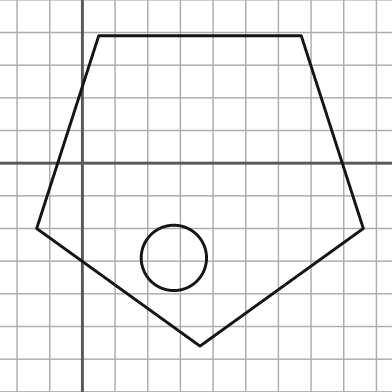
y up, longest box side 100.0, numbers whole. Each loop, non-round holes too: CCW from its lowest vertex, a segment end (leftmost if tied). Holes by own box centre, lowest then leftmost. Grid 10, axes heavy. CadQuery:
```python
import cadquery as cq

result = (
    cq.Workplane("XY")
    .moveTo(36.0, -56.0)
    .lineTo(86.0, -20.0)
    .lineTo(67.0, 39.0)
    .lineTo(5.0, 39.0)
    .lineTo(-14.0, -20.0)
    .close()
    .moveTo(28.0, -29.0)
    .circle(10.0)
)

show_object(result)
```